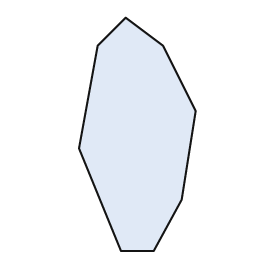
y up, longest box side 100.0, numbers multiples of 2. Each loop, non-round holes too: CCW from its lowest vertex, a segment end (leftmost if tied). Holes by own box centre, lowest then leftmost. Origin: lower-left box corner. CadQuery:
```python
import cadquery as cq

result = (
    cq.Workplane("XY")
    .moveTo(18.0, 0.0)
    .lineTo(32.0, 0.0)
    .lineTo(44.0, 22.0)
    .lineTo(50.0, 60.0)
    .lineTo(36.0, 88.0)
    .lineTo(20.0, 100.0)
    .lineTo(8.0, 88.0)
    .lineTo(0.0, 44.0)
    .close()
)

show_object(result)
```